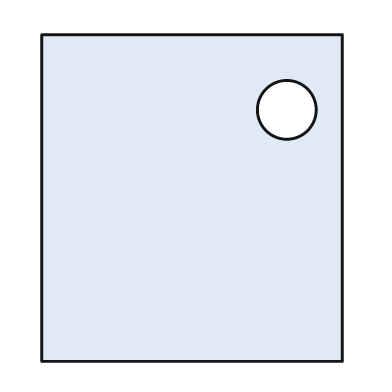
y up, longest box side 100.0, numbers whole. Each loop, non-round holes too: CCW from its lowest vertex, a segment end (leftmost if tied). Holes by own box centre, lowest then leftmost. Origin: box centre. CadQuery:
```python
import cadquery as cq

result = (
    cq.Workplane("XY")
    .moveTo(-46.0, -50.0)
    .lineTo(46.0, -50.0)
    .lineTo(46.0, 50.0)
    .lineTo(-46.0, 50.0)
    .close()
    .moveTo(29.0, 27.0)
    .circle(9.0)
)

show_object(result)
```